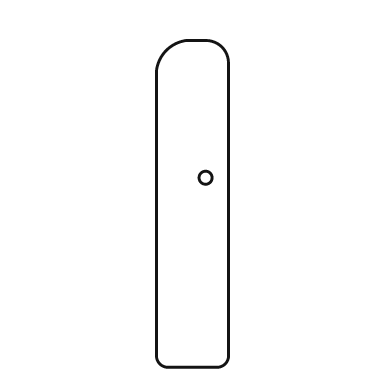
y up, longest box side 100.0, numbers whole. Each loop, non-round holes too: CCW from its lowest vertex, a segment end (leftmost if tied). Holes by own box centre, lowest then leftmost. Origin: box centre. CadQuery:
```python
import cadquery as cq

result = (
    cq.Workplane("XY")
    .moveTo(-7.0, -50.0)
    .lineTo(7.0, -50.0)
    .threePointArc((10.0, -49.0), (11.0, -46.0))
    .lineTo(11.0, 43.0)
    .threePointArc((9.0, 48.0), (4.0, 50.0))
    .lineTo(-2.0, 50.0)
    .threePointArc((-8.0, 47.0), (-11.0, 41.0))
    .lineTo(-11.0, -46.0)
    .threePointArc((-10.0, -49.0), (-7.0, -50.0))
    .close()
    .moveTo(4.0, 8.0)
    .circle(2.0)
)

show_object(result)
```